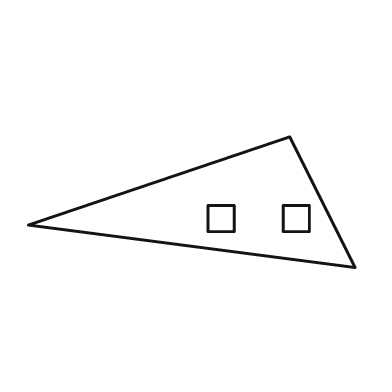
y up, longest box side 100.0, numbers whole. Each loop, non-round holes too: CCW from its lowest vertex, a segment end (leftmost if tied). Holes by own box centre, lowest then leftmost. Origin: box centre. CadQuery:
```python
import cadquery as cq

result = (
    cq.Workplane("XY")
    .moveTo(50.0, -20.0)
    .lineTo(30.0, 20.0)
    .lineTo(-50.0, -7.0)
    .close()
    .moveTo(5.0, -9.0)
    .lineTo(13.0, -9.0)
    .lineTo(13.0, -1.0)
    .lineTo(5.0, -1.0)
    .close()
    .moveTo(28.0, -9.0)
    .lineTo(36.0, -9.0)
    .lineTo(36.0, -1.0)
    .lineTo(28.0, -1.0)
    .close()
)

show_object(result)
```